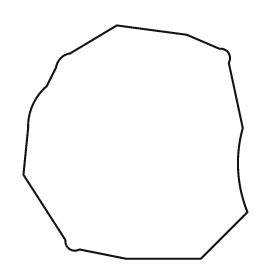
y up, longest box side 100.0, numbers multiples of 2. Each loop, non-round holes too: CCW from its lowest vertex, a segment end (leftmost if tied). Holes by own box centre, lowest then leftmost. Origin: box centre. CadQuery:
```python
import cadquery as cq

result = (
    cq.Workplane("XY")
    .moveTo(-4.0, -50.0)
    .lineTo(28.0, -50.0)
    .lineTo(48.0, -30.0)
    .threePointArc((44.0, -12.0), (46.0, 6.0))
    .lineTo(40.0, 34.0)
    .threePointArc((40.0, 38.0), (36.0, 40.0))
    .lineTo(22.0, 46.0)
    .lineTo(-8.0, 50.0)
    .lineTo(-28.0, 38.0)
    .threePointArc((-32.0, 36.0), (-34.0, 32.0))
    .lineTo(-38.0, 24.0)
    .threePointArc((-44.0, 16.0), (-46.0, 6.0))
    .lineTo(-48.0, -14.0)
    .lineTo(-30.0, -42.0)
    .threePointArc((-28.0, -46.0), (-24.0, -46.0))
    .close()
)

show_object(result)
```